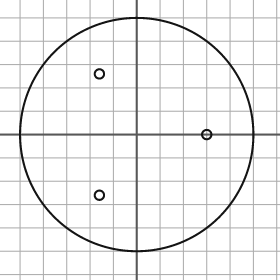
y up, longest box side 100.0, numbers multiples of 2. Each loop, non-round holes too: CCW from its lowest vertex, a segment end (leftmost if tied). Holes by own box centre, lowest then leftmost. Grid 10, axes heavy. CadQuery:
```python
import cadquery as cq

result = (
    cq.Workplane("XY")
    .moveTo(0.0, 0.0)
    .circle(50.0)
    .moveTo(-16.0, -26.0)
    .circle(2.0)
    .moveTo(30.0, 0.0)
    .circle(2.0)
    .moveTo(-16.0, 26.0)
    .circle(2.0)
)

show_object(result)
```